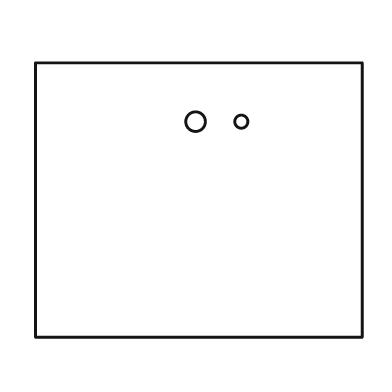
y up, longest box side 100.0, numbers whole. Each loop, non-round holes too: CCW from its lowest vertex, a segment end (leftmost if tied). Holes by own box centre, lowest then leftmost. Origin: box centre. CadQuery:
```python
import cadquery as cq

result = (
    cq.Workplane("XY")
    .moveTo(-50.0, -42.0)
    .lineTo(50.0, -42.0)
    .lineTo(50.0, 42.0)
    .lineTo(-50.0, 42.0)
    .close()
    .moveTo(-1.0, 24.0)
    .circle(3.0)
    .moveTo(13.0, 24.0)
    .circle(2.0)
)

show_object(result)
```